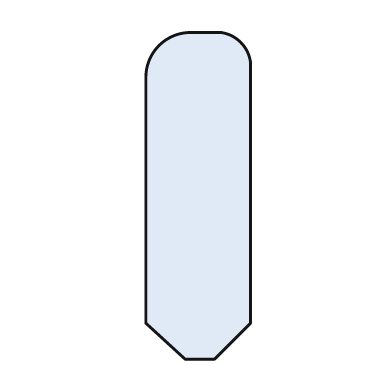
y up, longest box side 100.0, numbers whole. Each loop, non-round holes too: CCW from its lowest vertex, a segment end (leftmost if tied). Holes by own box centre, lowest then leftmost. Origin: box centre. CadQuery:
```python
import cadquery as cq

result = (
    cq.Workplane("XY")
    .moveTo(-4.0, -50.0)
    .lineTo(5.0, -50.0)
    .lineTo(16.0, -39.0)
    .lineTo(16.0, 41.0)
    .threePointArc((13.0, 47.0), (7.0, 50.0))
    .lineTo(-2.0, 50.0)
    .threePointArc((-12.0, 46.0), (-16.0, 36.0))
    .lineTo(-16.0, -39.0)
    .close()
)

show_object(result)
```